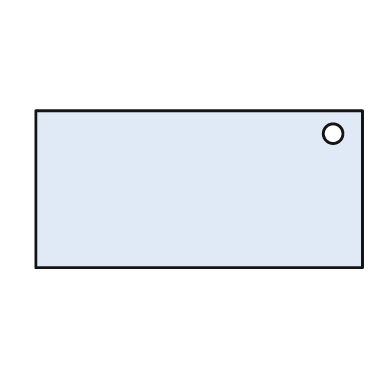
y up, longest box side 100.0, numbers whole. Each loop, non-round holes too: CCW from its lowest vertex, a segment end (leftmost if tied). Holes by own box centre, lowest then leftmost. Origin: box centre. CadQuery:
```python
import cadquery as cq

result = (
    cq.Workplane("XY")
    .moveTo(-50.0, -24.0)
    .lineTo(50.0, -24.0)
    .lineTo(50.0, 24.0)
    .lineTo(-50.0, 24.0)
    .close()
    .moveTo(41.0, 17.0)
    .circle(3.0)
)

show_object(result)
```